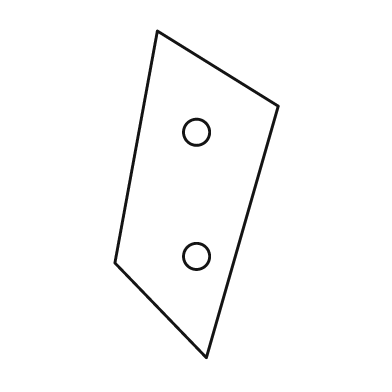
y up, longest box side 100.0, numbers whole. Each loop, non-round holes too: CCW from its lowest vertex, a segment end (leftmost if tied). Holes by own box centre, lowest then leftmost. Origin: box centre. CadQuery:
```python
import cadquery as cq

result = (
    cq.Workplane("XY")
    .moveTo(3.0, -50.0)
    .lineTo(25.0, 27.0)
    .lineTo(-12.0, 50.0)
    .lineTo(-25.0, -21.0)
    .close()
    .moveTo(0.0, -19.0)
    .circle(4.0)
    .moveTo(0.0, 19.0)
    .circle(4.0)
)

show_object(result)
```